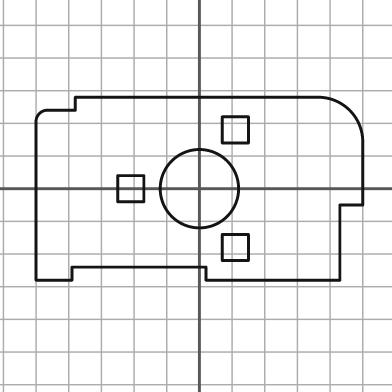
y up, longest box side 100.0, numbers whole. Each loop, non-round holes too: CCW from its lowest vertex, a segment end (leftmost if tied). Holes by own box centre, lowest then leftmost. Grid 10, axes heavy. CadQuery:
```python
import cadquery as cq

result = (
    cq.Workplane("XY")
    .moveTo(-50.0, -28.0)
    .lineTo(-39.0, -28.0)
    .lineTo(-39.0, -24.0)
    .lineTo(2.0, -24.0)
    .lineTo(2.0, -28.0)
    .lineTo(43.0, -28.0)
    .lineTo(43.0, -5.0)
    .lineTo(50.0, -5.0)
    .lineTo(50.0, 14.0)
    .threePointArc((46.0, 24.0), (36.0, 28.0))
    .lineTo(-38.0, 28.0)
    .lineTo(-38.0, 24.0)
    .lineTo(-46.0, 24.0)
    .threePointArc((-49.0, 23.0), (-50.0, 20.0))
    .close()
    .moveTo(7.0, -22.0)
    .lineTo(15.0, -22.0)
    .lineTo(15.0, -14.0)
    .lineTo(7.0, -14.0)
    .close()
    .moveTo(-25.0, -4.0)
    .lineTo(-17.0, -4.0)
    .lineTo(-17.0, 4.0)
    .lineTo(-25.0, 4.0)
    .close()
    .moveTo(0.0, 0.0)
    .circle(12.0)
    .moveTo(7.0, 14.0)
    .lineTo(15.0, 14.0)
    .lineTo(15.0, 22.0)
    .lineTo(7.0, 22.0)
    .close()
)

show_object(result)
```